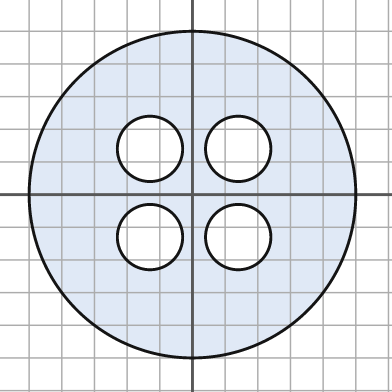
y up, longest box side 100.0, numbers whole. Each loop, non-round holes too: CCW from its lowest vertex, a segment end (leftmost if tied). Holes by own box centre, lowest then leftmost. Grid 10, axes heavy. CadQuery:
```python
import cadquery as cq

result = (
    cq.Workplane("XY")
    .moveTo(0.0, 0.0)
    .circle(50.0)
    .moveTo(-13.0, -13.0)
    .circle(10.0)
    .moveTo(14.0, -13.0)
    .circle(10.0)
    .moveTo(-13.0, 14.0)
    .circle(10.0)
    .moveTo(14.0, 14.0)
    .circle(10.0)
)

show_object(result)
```